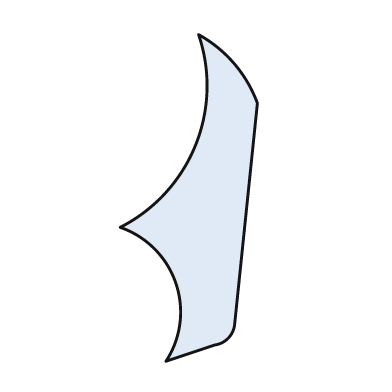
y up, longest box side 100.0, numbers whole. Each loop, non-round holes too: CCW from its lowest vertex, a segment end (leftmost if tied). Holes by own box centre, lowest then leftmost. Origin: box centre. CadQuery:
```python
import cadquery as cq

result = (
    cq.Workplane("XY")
    .moveTo(-7.0, -50.0)
    .lineTo(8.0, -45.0)
    .threePointArc((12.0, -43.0), (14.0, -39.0))
    .lineTo(21.0, 29.0)
    .threePointArc((14.0, 41.0), (3.0, 50.0))
    .threePointArc((2.0, 16.0), (-21.0, -9.0))
    .threePointArc((-4.0, -26.0), (-7.0, -50.0))
    .close()
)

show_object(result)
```